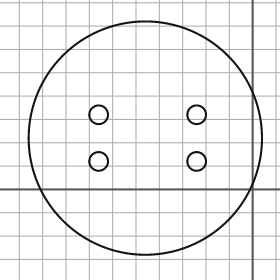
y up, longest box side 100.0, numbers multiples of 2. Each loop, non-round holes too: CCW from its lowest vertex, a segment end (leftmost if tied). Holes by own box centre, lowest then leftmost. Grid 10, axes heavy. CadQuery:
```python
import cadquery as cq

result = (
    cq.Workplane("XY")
    .moveTo(-46.0, 22.0)
    .circle(50.0)
    .moveTo(-66.0, 12.0)
    .circle(4.0)
    .moveTo(-24.0, 12.0)
    .circle(4.0)
    .moveTo(-66.0, 32.0)
    .circle(4.0)
    .moveTo(-24.0, 32.0)
    .circle(4.0)
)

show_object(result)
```